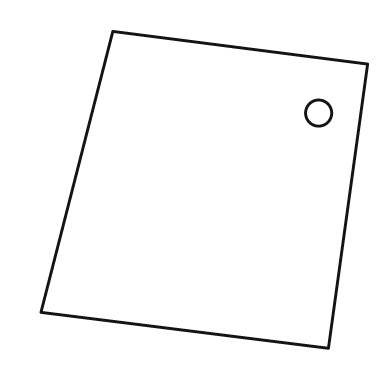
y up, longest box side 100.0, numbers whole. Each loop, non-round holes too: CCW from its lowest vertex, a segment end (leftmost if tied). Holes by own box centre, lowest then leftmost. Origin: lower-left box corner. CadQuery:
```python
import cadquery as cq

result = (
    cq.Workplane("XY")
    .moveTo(88.0, 0.0)
    .lineTo(100.0, 87.0)
    .lineTo(22.0, 97.0)
    .lineTo(0.0, 11.0)
    .close()
    .moveTo(85.0, 72.0)
    .circle(4.0)
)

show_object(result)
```